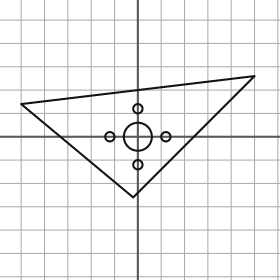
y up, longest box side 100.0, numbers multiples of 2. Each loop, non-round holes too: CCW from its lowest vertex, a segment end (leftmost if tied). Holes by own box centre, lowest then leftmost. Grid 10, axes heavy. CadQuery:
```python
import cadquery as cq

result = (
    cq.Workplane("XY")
    .moveTo(-2.0, -26.0)
    .lineTo(50.0, 26.0)
    .lineTo(-50.0, 14.0)
    .close()
    .moveTo(0.0, -12.0)
    .circle(2.0)
    .moveTo(-12.0, 0.0)
    .circle(2.0)
    .moveTo(0.0, 0.0)
    .circle(6.0)
    .moveTo(12.0, 0.0)
    .circle(2.0)
    .moveTo(0.0, 12.0)
    .circle(2.0)
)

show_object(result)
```